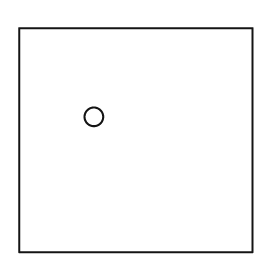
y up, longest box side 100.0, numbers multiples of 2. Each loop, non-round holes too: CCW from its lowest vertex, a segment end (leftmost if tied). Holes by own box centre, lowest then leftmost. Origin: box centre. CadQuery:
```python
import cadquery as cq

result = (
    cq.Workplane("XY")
    .moveTo(-50.0, -48.0)
    .lineTo(50.0, -48.0)
    .lineTo(50.0, 48.0)
    .lineTo(-50.0, 48.0)
    .close()
    .moveTo(-18.0, 10.0)
    .circle(4.0)
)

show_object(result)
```